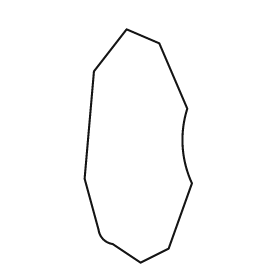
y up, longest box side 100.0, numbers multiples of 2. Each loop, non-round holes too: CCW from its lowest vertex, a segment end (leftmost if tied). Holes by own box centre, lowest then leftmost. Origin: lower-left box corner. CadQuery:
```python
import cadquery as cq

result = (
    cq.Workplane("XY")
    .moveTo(24.0, 0.0)
    .lineTo(36.0, 6.0)
    .lineTo(46.0, 34.0)
    .threePointArc((42.0, 50.0), (44.0, 66.0))
    .lineTo(32.0, 94.0)
    .lineTo(18.0, 100.0)
    .lineTo(4.0, 82.0)
    .lineTo(0.0, 36.0)
    .lineTo(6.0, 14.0)
    .threePointArc((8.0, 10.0), (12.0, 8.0))
    .close()
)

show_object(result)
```